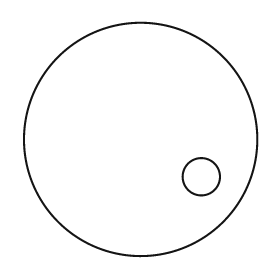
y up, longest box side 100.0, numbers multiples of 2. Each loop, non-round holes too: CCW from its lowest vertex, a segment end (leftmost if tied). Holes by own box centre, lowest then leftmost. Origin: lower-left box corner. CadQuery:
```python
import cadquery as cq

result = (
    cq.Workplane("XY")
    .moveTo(50.0, 50.0)
    .circle(50.0)
    .moveTo(76.0, 34.0)
    .circle(8.0)
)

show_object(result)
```